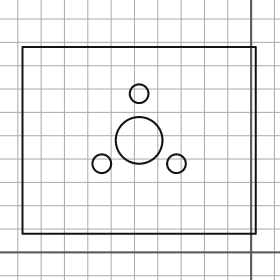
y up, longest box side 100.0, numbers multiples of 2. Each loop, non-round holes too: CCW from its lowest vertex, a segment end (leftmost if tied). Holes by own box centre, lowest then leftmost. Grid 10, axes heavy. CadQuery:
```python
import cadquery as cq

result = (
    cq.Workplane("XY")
    .moveTo(-98.0, 8.0)
    .lineTo(2.0, 8.0)
    .lineTo(2.0, 88.0)
    .lineTo(-98.0, 88.0)
    .close()
    .moveTo(-64.0, 38.0)
    .circle(4.0)
    .moveTo(-32.0, 38.0)
    .circle(4.0)
    .moveTo(-48.0, 48.0)
    .circle(10.0)
    .moveTo(-48.0, 68.0)
    .circle(4.0)
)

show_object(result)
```